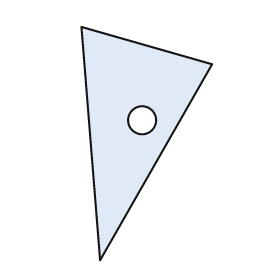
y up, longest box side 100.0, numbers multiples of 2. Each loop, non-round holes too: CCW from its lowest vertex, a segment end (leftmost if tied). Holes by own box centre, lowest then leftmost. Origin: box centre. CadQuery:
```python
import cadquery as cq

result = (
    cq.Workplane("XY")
    .moveTo(-20.0, -50.0)
    .lineTo(28.0, 34.0)
    .lineTo(-28.0, 50.0)
    .close()
    .moveTo(-2.0, 10.0)
    .circle(6.0)
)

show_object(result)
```